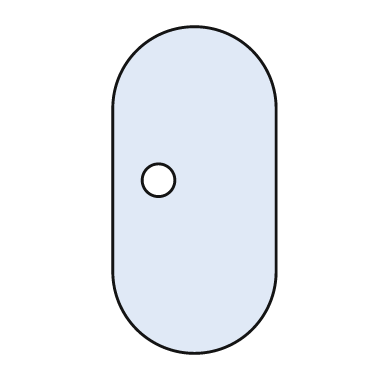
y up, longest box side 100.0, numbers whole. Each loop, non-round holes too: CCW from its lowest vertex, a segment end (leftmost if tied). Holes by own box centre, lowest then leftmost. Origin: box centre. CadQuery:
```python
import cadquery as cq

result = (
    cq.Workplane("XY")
    .moveTo(-25.0, -25.0)
    .threePointArc((0.0, -50.0), (25.0, -25.0))
    .lineTo(25.0, 25.0)
    .threePointArc((0.0, 50.0), (-25.0, 25.0))
    .close()
    .moveTo(-11.0, 3.0)
    .circle(5.0)
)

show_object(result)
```